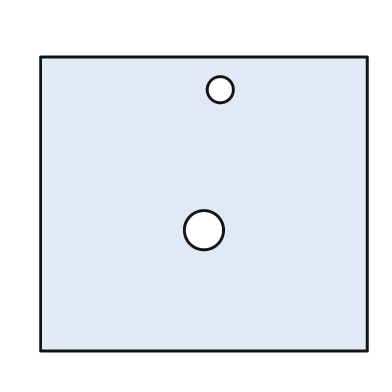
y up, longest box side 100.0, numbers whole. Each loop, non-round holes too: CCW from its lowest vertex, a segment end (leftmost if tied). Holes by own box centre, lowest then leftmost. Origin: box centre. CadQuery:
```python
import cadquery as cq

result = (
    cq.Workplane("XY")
    .moveTo(-50.0, -45.0)
    .lineTo(50.0, -45.0)
    .lineTo(50.0, 45.0)
    .lineTo(-50.0, 45.0)
    .close()
    .moveTo(0.0, -8.0)
    .circle(6.0)
    .moveTo(5.0, 35.0)
    .circle(4.0)
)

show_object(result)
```